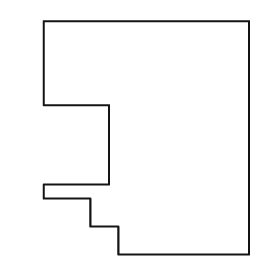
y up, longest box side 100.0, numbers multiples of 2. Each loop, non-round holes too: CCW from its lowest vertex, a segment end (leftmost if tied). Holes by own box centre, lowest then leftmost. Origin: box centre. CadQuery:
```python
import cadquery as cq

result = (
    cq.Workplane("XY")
    .moveTo(-12.0, -50.0)
    .lineTo(44.0, -50.0)
    .lineTo(44.0, 50.0)
    .lineTo(-44.0, 50.0)
    .lineTo(-44.0, 14.0)
    .lineTo(-16.0, 14.0)
    .lineTo(-16.0, -20.0)
    .lineTo(-44.0, -20.0)
    .lineTo(-44.0, -26.0)
    .lineTo(-24.0, -26.0)
    .lineTo(-24.0, -38.0)
    .lineTo(-12.0, -38.0)
    .close()
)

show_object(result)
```